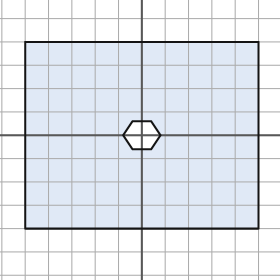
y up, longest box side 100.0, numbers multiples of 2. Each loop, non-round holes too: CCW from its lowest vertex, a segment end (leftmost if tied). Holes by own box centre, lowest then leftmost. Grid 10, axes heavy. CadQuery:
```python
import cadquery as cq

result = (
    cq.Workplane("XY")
    .moveTo(-50.0, -40.0)
    .lineTo(50.0, -40.0)
    .lineTo(50.0, 40.0)
    .lineTo(-50.0, 40.0)
    .close()
    .moveTo(-4.0, -6.0)
    .lineTo(4.0, -6.0)
    .lineTo(8.0, 0.0)
    .lineTo(4.0, 6.0)
    .lineTo(-4.0, 6.0)
    .lineTo(-8.0, 0.0)
    .close()
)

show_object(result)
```